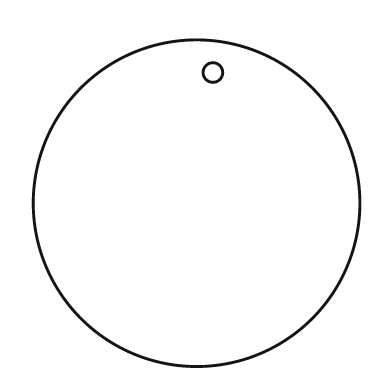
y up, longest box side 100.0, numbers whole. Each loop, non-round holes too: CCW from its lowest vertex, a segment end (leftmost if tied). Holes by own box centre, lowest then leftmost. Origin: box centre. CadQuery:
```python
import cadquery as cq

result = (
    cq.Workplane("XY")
    .moveTo(0.0, 0.0)
    .circle(50.0)
    .moveTo(5.0, 40.0)
    .circle(3.0)
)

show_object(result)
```